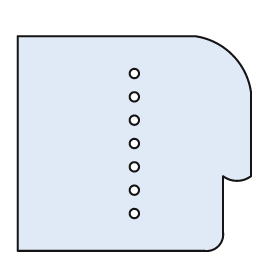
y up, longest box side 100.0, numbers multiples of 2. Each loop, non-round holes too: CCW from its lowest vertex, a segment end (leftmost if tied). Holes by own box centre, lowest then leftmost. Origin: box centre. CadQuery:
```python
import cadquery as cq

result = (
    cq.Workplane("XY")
    .moveTo(-50.0, -46.0)
    .lineTo(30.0, -46.0)
    .threePointArc((36.0, -44.0), (38.0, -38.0))
    .lineTo(38.0, -14.0)
    .threePointArc((44.0, -16.0), (50.0, -14.0))
    .lineTo(50.0, 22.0)
    .threePointArc((42.0, 38.0), (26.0, 46.0))
    .lineTo(-50.0, 46.0)
    .close()
    .moveTo(0.0, -30.0)
    .circle(2.0)
    .moveTo(0.0, -20.0)
    .circle(2.0)
    .moveTo(0.0, -10.0)
    .circle(2.0)
    .moveTo(0.0, 0.0)
    .circle(2.0)
    .moveTo(0.0, 10.0)
    .circle(2.0)
    .moveTo(0.0, 20.0)
    .circle(2.0)
    .moveTo(0.0, 30.0)
    .circle(2.0)
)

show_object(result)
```